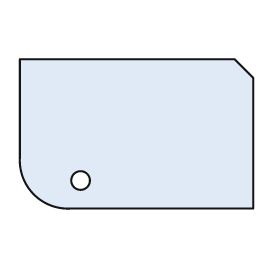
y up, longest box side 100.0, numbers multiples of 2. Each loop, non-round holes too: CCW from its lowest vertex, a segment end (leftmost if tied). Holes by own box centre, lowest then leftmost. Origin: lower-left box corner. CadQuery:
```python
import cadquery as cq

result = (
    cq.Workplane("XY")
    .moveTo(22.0, 0.0)
    .lineTo(100.0, 0.0)
    .lineTo(100.0, 56.0)
    .lineTo(92.0, 64.0)
    .lineTo(0.0, 64.0)
    .lineTo(0.0, 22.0)
    .threePointArc((6.0, 6.0), (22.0, 0.0))
    .close()
    .moveTo(26.0, 12.0)
    .circle(4.0)
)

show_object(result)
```